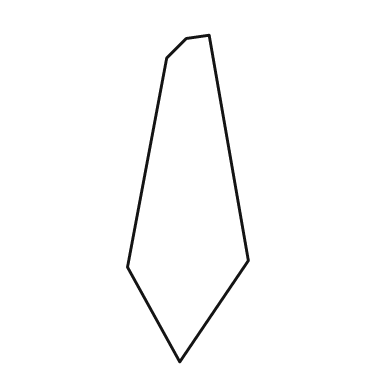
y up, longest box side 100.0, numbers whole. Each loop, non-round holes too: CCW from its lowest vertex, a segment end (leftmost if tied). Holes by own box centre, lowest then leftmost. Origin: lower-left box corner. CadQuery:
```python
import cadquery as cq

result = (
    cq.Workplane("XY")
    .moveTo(16.0, 0.0)
    .lineTo(37.0, 31.0)
    .lineTo(25.0, 100.0)
    .lineTo(18.0, 99.0)
    .lineTo(12.0, 93.0)
    .lineTo(0.0, 29.0)
    .close()
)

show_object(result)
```